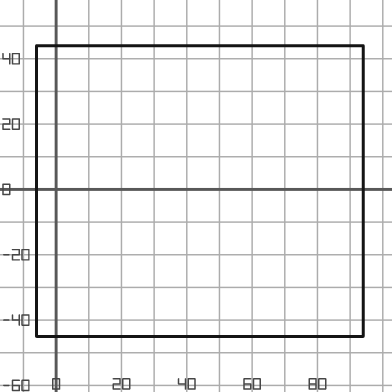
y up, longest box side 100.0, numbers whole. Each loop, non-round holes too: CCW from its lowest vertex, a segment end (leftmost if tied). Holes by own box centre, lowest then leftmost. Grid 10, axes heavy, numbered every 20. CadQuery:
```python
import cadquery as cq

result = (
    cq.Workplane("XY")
    .moveTo(-6.0, -45.0)
    .lineTo(94.0, -45.0)
    .lineTo(94.0, 44.0)
    .lineTo(-6.0, 44.0)
    .close()
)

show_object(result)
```